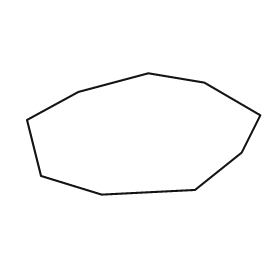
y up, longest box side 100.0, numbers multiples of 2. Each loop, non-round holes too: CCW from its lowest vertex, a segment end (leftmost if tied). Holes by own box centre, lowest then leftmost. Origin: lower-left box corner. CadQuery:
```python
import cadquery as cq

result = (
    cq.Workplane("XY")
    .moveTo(32.0, 0.0)
    .lineTo(72.0, 2.0)
    .lineTo(92.0, 18.0)
    .lineTo(100.0, 34.0)
    .lineTo(76.0, 48.0)
    .lineTo(52.0, 52.0)
    .lineTo(22.0, 44.0)
    .lineTo(0.0, 32.0)
    .lineTo(6.0, 8.0)
    .close()
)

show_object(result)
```